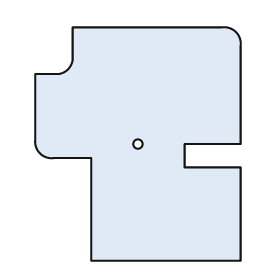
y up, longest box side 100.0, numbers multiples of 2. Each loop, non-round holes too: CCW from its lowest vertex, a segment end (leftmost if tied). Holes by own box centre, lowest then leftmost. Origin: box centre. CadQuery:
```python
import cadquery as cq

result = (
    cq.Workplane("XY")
    .moveTo(-20.0, -50.0)
    .lineTo(44.0, -50.0)
    .lineTo(44.0, -10.0)
    .lineTo(20.0, -10.0)
    .lineTo(20.0, 0.0)
    .lineTo(44.0, 0.0)
    .lineTo(44.0, 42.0)
    .threePointArc((42.0, 48.0), (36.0, 50.0))
    .lineTo(-28.0, 50.0)
    .lineTo(-28.0, 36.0)
    .threePointArc((-30.0, 32.0), (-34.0, 30.0))
    .lineTo(-44.0, 30.0)
    .lineTo(-44.0, 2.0)
    .threePointArc((-42.0, -4.0), (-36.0, -6.0))
    .lineTo(-20.0, -6.0)
    .close()
    .moveTo(0.0, 0.0)
    .circle(2.0)
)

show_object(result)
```